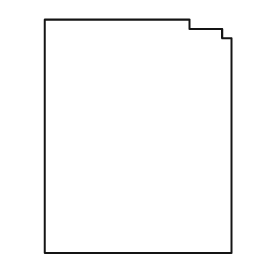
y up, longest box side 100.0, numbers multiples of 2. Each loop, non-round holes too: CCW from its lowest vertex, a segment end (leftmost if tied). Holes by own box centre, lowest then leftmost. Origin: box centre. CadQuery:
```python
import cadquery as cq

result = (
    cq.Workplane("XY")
    .moveTo(-40.0, -50.0)
    .lineTo(40.0, -50.0)
    .lineTo(40.0, 42.0)
    .lineTo(36.0, 42.0)
    .lineTo(36.0, 46.0)
    .lineTo(22.0, 46.0)
    .lineTo(22.0, 50.0)
    .lineTo(-40.0, 50.0)
    .close()
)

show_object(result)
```